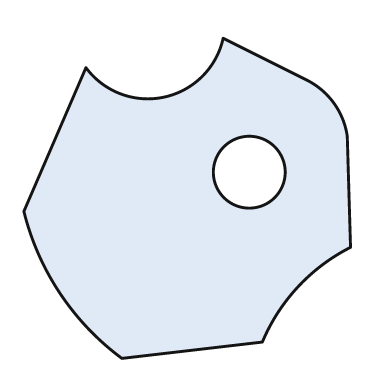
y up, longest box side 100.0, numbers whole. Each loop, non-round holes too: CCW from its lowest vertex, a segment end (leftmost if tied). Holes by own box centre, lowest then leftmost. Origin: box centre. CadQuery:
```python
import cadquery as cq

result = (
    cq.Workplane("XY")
    .moveTo(-20.0, -49.0)
    .lineTo(23.0, -44.0)
    .threePointArc((34.0, -27.0), (50.0, -15.0))
    .lineTo(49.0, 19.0)
    .threePointArc((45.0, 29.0), (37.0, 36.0))
    .lineTo(11.0, 49.0)
    .threePointArc((-7.0, 31.0), (-31.0, 40.0))
    .lineTo(-50.0, -4.0)
    .threePointArc((-39.0, -29.0), (-20.0, -49.0))
    .close()
    .moveTo(19.0, 8.0)
    .circle(11.0)
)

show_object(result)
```